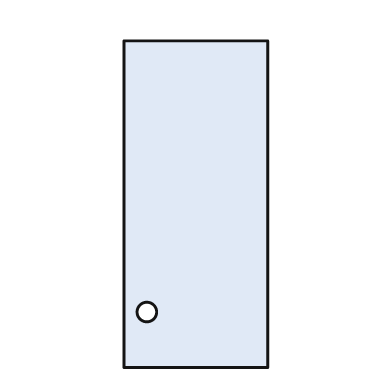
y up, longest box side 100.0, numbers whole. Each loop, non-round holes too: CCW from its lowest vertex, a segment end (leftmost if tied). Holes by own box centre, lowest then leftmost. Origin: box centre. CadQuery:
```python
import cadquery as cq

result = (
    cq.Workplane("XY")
    .moveTo(-22.0, -50.0)
    .lineTo(22.0, -50.0)
    .lineTo(22.0, 50.0)
    .lineTo(-22.0, 50.0)
    .close()
    .moveTo(-15.0, -33.0)
    .circle(3.0)
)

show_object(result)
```